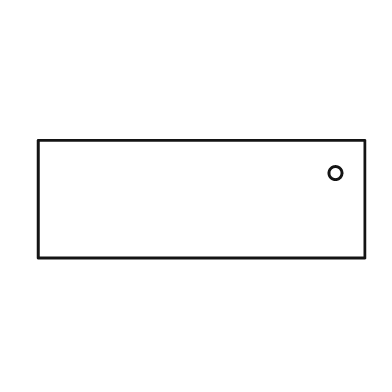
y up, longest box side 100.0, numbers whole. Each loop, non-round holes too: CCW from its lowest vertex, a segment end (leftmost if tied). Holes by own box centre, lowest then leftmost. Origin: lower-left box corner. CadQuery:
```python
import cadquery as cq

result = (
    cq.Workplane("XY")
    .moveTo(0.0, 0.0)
    .lineTo(100.0, 0.0)
    .lineTo(100.0, 36.0)
    .lineTo(0.0, 36.0)
    .close()
    .moveTo(91.0, 26.0)
    .circle(2.0)
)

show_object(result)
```